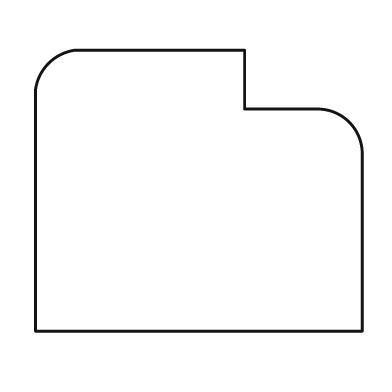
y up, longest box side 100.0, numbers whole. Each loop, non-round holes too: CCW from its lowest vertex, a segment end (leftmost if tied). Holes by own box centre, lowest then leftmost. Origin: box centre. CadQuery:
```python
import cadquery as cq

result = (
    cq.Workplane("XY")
    .moveTo(-50.0, -43.0)
    .lineTo(50.0, -43.0)
    .lineTo(50.0, 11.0)
    .threePointArc((46.0, 21.0), (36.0, 25.0))
    .lineTo(14.0, 25.0)
    .lineTo(14.0, 43.0)
    .lineTo(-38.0, 43.0)
    .threePointArc((-46.0, 39.0), (-50.0, 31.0))
    .close()
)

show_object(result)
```